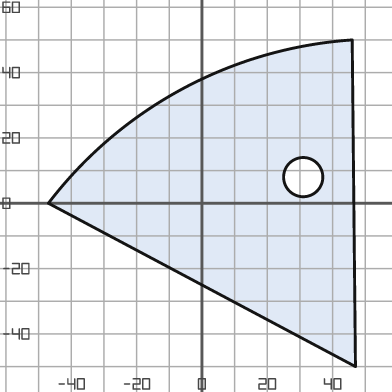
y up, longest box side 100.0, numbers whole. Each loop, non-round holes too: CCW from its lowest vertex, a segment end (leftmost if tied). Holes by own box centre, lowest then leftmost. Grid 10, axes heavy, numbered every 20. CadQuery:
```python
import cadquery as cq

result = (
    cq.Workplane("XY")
    .moveTo(47.0, -50.0)
    .lineTo(46.0, 50.0)
    .threePointArc((-6.0, 35.0), (-47.0, 0.0))
    .close()
    .moveTo(31.0, 8.0)
    .circle(6.0)
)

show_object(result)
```